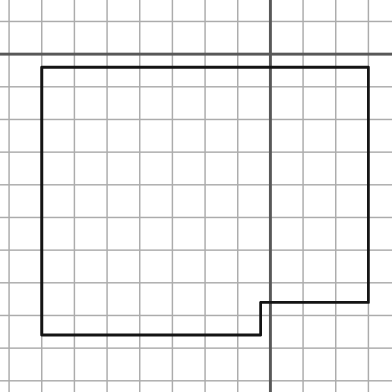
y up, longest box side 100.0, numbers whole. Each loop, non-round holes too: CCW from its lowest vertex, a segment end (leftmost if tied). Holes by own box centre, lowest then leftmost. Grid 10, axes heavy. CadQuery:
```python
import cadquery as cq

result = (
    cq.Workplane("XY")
    .moveTo(-70.0, -86.0)
    .lineTo(-3.0, -86.0)
    .lineTo(-3.0, -76.0)
    .lineTo(30.0, -76.0)
    .lineTo(30.0, -4.0)
    .lineTo(-70.0, -4.0)
    .close()
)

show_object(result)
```